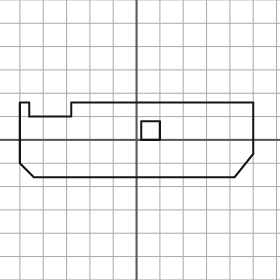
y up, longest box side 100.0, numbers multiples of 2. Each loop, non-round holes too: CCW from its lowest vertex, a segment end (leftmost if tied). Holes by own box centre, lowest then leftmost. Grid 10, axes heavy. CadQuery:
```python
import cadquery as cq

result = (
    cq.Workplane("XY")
    .moveTo(-44.0, -16.0)
    .lineTo(42.0, -16.0)
    .lineTo(50.0, -6.0)
    .lineTo(50.0, 16.0)
    .lineTo(-28.0, 16.0)
    .lineTo(-28.0, 10.0)
    .lineTo(-46.0, 10.0)
    .lineTo(-46.0, 16.0)
    .lineTo(-50.0, 16.0)
    .lineTo(-50.0, -10.0)
    .close()
    .moveTo(2.0, 0.0)
    .lineTo(10.0, 0.0)
    .lineTo(10.0, 8.0)
    .lineTo(2.0, 8.0)
    .close()
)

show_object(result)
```